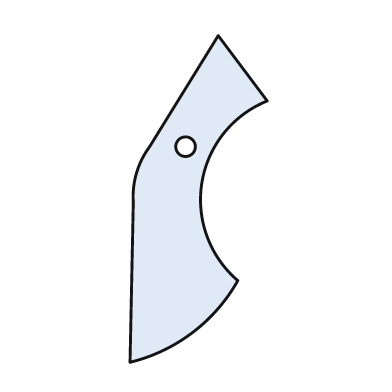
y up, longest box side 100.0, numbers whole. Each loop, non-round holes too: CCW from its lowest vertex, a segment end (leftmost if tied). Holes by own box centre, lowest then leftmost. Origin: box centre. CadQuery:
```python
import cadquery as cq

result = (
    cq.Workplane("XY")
    .moveTo(-21.0, -50.0)
    .threePointArc((-2.0, -41.0), (12.0, -25.0))
    .threePointArc((1.0, 5.0), (21.0, 30.0))
    .lineTo(6.0, 50.0)
    .lineTo(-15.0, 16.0)
    .threePointArc((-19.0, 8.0), (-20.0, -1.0))
    .close()
    .moveTo(-4.0, 16.0)
    .circle(3.0)
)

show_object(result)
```